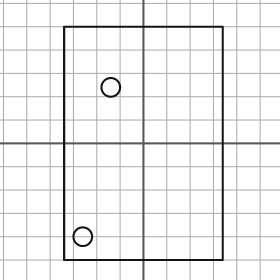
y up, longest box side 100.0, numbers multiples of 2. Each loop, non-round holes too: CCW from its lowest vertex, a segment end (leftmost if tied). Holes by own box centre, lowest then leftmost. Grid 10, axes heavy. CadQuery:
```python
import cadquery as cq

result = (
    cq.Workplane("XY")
    .moveTo(-34.0, -50.0)
    .lineTo(34.0, -50.0)
    .lineTo(34.0, 50.0)
    .lineTo(-34.0, 50.0)
    .close()
    .moveTo(-26.0, -40.0)
    .circle(4.0)
    .moveTo(-14.0, 24.0)
    .circle(4.0)
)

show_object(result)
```